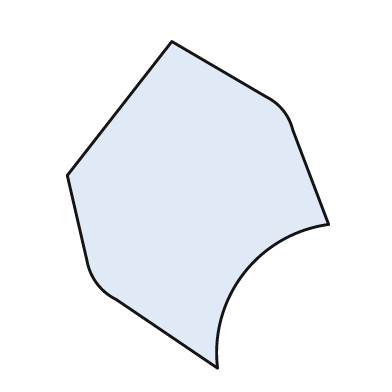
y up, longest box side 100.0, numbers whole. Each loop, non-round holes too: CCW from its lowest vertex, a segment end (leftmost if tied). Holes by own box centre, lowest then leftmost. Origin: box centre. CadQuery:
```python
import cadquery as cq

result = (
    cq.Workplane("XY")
    .moveTo(6.0, -50.0)
    .threePointArc((14.0, -21.0), (40.0, -6.0))
    .lineTo(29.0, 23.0)
    .threePointArc((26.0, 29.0), (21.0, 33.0))
    .lineTo(-8.0, 50.0)
    .lineTo(-40.0, 9.0)
    .lineTo(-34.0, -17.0)
    .threePointArc((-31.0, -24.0), (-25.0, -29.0))
    .close()
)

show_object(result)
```